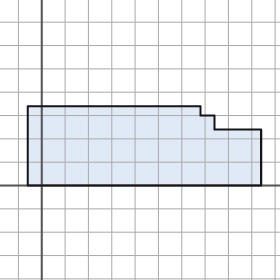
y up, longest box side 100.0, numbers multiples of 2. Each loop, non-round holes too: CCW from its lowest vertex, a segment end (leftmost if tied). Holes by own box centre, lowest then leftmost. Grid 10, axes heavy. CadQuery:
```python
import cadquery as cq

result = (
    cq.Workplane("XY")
    .moveTo(-6.0, 0.0)
    .lineTo(94.0, 0.0)
    .lineTo(94.0, 24.0)
    .lineTo(74.0, 24.0)
    .lineTo(74.0, 30.0)
    .lineTo(68.0, 30.0)
    .lineTo(68.0, 34.0)
    .lineTo(-6.0, 34.0)
    .close()
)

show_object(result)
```